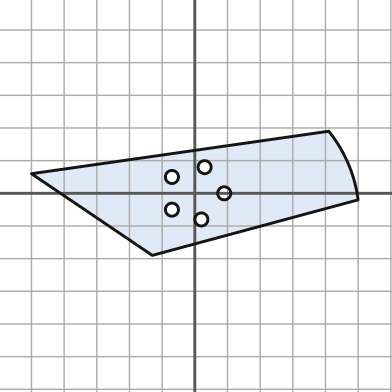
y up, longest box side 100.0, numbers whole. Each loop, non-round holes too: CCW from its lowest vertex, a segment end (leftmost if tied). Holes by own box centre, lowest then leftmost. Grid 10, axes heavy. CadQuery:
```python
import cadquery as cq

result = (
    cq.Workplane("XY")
    .moveTo(-13.0, -19.0)
    .lineTo(50.0, -2.0)
    .threePointArc((47.0, 9.0), (41.0, 19.0))
    .lineTo(-50.0, 6.0)
    .close()
    .moveTo(2.0, -8.0)
    .circle(2.0)
    .moveTo(-7.0, -5.0)
    .circle(2.0)
    .moveTo(9.0, 0.0)
    .circle(2.0)
    .moveTo(-7.0, 5.0)
    .circle(2.0)
    .moveTo(3.0, 8.0)
    .circle(2.0)
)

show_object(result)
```